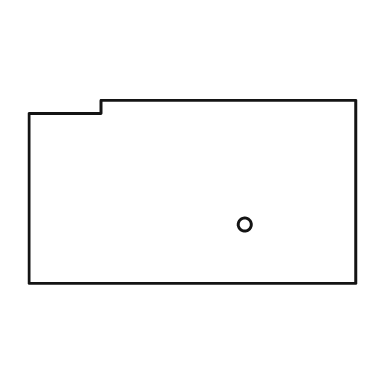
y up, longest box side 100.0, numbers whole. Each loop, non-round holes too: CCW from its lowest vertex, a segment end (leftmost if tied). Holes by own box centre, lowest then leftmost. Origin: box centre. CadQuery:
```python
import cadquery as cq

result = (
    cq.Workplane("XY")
    .moveTo(-50.0, -28.0)
    .lineTo(50.0, -28.0)
    .lineTo(50.0, 28.0)
    .lineTo(-28.0, 28.0)
    .lineTo(-28.0, 24.0)
    .lineTo(-50.0, 24.0)
    .close()
    .moveTo(16.0, -10.0)
    .circle(2.0)
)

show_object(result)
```